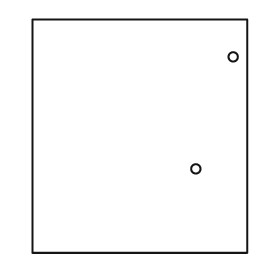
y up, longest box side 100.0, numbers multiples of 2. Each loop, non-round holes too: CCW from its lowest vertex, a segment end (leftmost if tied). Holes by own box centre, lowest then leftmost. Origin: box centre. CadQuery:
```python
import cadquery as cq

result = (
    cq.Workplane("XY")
    .moveTo(-46.0, -50.0)
    .lineTo(46.0, -50.0)
    .lineTo(46.0, 50.0)
    .lineTo(-46.0, 50.0)
    .close()
    .moveTo(24.0, -14.0)
    .circle(2.0)
    .moveTo(40.0, 34.0)
    .circle(2.0)
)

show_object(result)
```